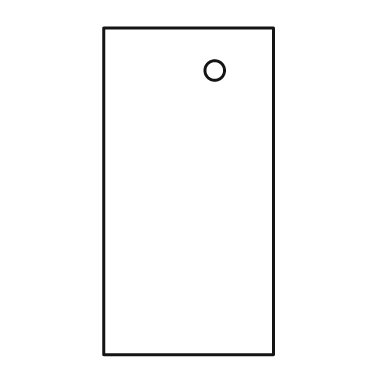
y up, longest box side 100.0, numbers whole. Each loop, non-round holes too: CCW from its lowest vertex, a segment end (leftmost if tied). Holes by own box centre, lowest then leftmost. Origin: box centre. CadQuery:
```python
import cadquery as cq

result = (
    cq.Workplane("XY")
    .moveTo(-26.0, -50.0)
    .lineTo(26.0, -50.0)
    .lineTo(26.0, 50.0)
    .lineTo(-26.0, 50.0)
    .close()
    .moveTo(8.0, 37.0)
    .circle(3.0)
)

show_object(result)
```